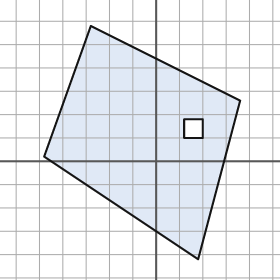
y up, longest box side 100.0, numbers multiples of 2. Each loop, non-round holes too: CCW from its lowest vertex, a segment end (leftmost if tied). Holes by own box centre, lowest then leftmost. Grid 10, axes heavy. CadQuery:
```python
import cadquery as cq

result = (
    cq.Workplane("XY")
    .moveTo(18.0, -42.0)
    .lineTo(36.0, 26.0)
    .lineTo(-28.0, 58.0)
    .lineTo(-48.0, 2.0)
    .close()
    .moveTo(12.0, 10.0)
    .lineTo(20.0, 10.0)
    .lineTo(20.0, 18.0)
    .lineTo(12.0, 18.0)
    .close()
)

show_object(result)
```